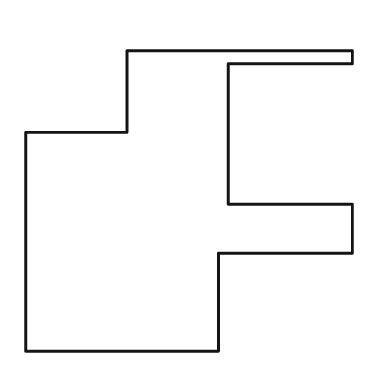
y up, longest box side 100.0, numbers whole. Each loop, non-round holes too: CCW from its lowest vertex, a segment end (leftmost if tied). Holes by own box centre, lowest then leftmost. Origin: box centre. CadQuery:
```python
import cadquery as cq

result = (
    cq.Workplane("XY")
    .moveTo(-50.0, -46.0)
    .lineTo(9.0, -46.0)
    .lineTo(9.0, -16.0)
    .lineTo(50.0, -16.0)
    .lineTo(50.0, -1.0)
    .lineTo(12.0, -1.0)
    .lineTo(12.0, 42.0)
    .lineTo(50.0, 42.0)
    .lineTo(50.0, 46.0)
    .lineTo(-19.0, 46.0)
    .lineTo(-19.0, 21.0)
    .lineTo(-50.0, 21.0)
    .close()
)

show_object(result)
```